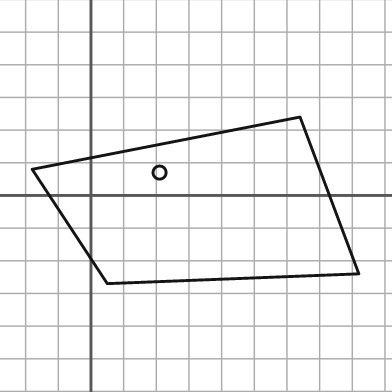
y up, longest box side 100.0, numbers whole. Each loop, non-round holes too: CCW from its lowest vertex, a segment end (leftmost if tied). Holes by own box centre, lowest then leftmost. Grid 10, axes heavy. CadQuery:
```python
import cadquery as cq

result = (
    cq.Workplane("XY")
    .moveTo(5.0, -27.0)
    .lineTo(82.0, -24.0)
    .lineTo(64.0, 24.0)
    .lineTo(-18.0, 8.0)
    .close()
    .moveTo(21.0, 7.0)
    .circle(2.0)
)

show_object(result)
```